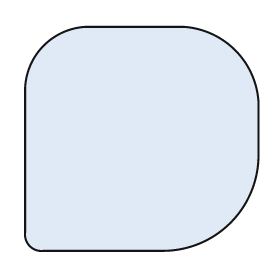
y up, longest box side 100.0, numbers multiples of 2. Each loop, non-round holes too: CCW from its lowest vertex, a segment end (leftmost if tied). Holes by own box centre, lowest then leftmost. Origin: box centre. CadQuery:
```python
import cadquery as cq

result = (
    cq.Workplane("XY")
    .moveTo(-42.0, -48.0)
    .lineTo(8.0, -48.0)
    .threePointArc((38.0, -36.0), (50.0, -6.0))
    .lineTo(50.0, 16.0)
    .threePointArc((40.0, 38.0), (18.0, 48.0))
    .lineTo(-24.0, 48.0)
    .threePointArc((-42.0, 40.0), (-50.0, 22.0))
    .lineTo(-50.0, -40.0)
    .threePointArc((-48.0, -46.0), (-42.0, -48.0))
    .close()
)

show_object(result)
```